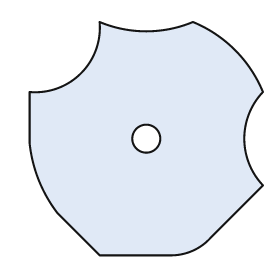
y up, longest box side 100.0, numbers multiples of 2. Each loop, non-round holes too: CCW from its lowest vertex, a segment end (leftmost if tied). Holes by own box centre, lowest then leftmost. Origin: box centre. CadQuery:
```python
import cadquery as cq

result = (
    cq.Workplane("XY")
    .moveTo(-20.0, -50.0)
    .lineTo(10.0, -50.0)
    .threePointArc((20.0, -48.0), (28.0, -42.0))
    .lineTo(50.0, -20.0)
    .threePointArc((42.0, 0.0), (50.0, 20.0))
    .threePointArc((38.0, 38.0), (20.0, 50.0))
    .threePointArc((0.0, 46.0), (-20.0, 50.0))
    .threePointArc((-28.0, 28.0), (-50.0, 20.0))
    .lineTo(-50.0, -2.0)
    .threePointArc((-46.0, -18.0), (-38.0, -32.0))
    .close()
    .moveTo(0.0, 0.0)
    .circle(6.0)
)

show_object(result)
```